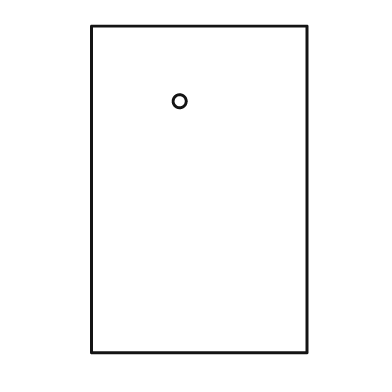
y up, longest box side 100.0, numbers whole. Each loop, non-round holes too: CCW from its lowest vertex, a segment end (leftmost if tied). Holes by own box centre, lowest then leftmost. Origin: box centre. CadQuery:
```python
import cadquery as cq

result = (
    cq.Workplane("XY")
    .moveTo(-33.0, -50.0)
    .lineTo(33.0, -50.0)
    .lineTo(33.0, 50.0)
    .lineTo(-33.0, 50.0)
    .close()
    .moveTo(-6.0, 27.0)
    .circle(2.0)
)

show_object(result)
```